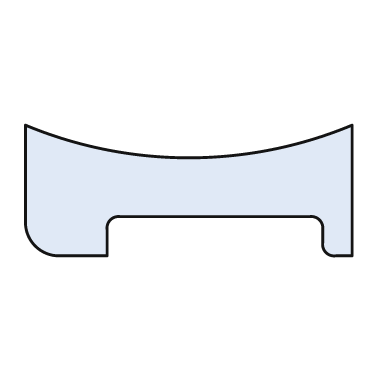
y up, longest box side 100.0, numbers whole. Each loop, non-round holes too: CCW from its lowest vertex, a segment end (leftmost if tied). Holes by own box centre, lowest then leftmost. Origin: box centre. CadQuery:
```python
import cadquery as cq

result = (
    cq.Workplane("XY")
    .moveTo(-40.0, -20.0)
    .lineTo(-25.0, -20.0)
    .lineTo(-25.0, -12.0)
    .threePointArc((-24.0, -9.0), (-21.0, -8.0))
    .lineTo(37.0, -8.0)
    .threePointArc((40.0, -9.0), (41.0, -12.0))
    .lineTo(41.0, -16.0)
    .threePointArc((42.0, -19.0), (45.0, -20.0))
    .lineTo(50.0, -20.0)
    .lineTo(50.0, 20.0)
    .threePointArc((0.0, 10.0), (-50.0, 20.0))
    .lineTo(-50.0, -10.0)
    .threePointArc((-47.0, -17.0), (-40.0, -20.0))
    .close()
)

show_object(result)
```